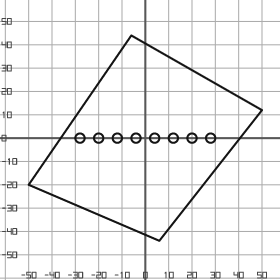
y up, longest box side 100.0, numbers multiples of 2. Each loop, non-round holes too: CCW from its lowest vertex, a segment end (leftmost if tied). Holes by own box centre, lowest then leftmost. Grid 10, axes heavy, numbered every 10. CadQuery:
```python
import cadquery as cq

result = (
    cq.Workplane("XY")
    .moveTo(6.0, -44.0)
    .lineTo(50.0, 12.0)
    .lineTo(-6.0, 44.0)
    .lineTo(-50.0, -20.0)
    .close()
    .moveTo(-28.0, 0.0)
    .circle(2.0)
    .moveTo(-20.0, 0.0)
    .circle(2.0)
    .moveTo(-12.0, 0.0)
    .circle(2.0)
    .moveTo(-4.0, 0.0)
    .circle(2.0)
    .moveTo(4.0, 0.0)
    .circle(2.0)
    .moveTo(12.0, 0.0)
    .circle(2.0)
    .moveTo(20.0, 0.0)
    .circle(2.0)
    .moveTo(28.0, 0.0)
    .circle(2.0)
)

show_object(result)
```